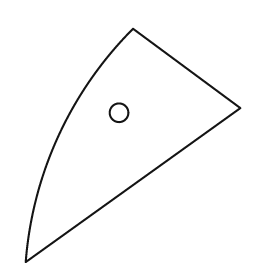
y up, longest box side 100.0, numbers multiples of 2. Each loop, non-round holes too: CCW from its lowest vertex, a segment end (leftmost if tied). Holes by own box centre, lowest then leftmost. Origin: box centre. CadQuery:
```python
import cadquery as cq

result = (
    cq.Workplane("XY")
    .moveTo(-46.0, -50.0)
    .lineTo(46.0, 16.0)
    .lineTo(0.0, 50.0)
    .threePointArc((-32.0, 4.0), (-46.0, -50.0))
    .close()
    .moveTo(-6.0, 14.0)
    .circle(4.0)
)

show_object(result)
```